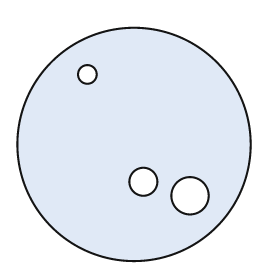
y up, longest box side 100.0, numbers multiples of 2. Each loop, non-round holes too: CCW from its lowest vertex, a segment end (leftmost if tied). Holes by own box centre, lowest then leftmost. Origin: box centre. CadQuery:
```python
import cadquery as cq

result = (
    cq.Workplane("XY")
    .moveTo(0.0, 0.0)
    .circle(50.0)
    .moveTo(24.0, -22.0)
    .circle(8.0)
    .moveTo(4.0, -16.0)
    .circle(6.0)
    .moveTo(-20.0, 30.0)
    .circle(4.0)
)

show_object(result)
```